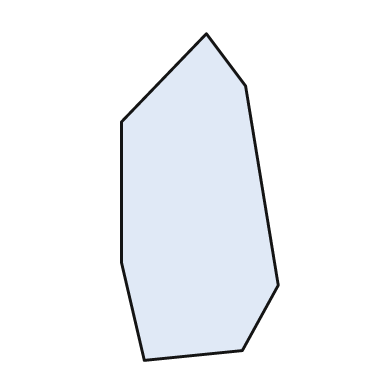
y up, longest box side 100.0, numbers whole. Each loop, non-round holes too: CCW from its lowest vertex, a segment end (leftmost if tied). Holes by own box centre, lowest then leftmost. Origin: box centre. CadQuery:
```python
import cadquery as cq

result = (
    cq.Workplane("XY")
    .moveTo(-17.0, -50.0)
    .lineTo(13.0, -47.0)
    .lineTo(24.0, -27.0)
    .lineTo(14.0, 34.0)
    .lineTo(2.0, 50.0)
    .lineTo(-24.0, 23.0)
    .lineTo(-24.0, -20.0)
    .close()
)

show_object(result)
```